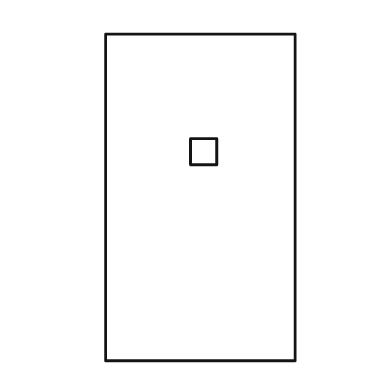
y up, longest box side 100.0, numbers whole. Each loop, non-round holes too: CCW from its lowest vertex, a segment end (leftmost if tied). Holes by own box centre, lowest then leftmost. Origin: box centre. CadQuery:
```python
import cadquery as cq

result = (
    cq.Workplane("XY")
    .moveTo(-29.0, -50.0)
    .lineTo(29.0, -50.0)
    .lineTo(29.0, 50.0)
    .lineTo(-29.0, 50.0)
    .close()
    .moveTo(-3.0, 10.0)
    .lineTo(5.0, 10.0)
    .lineTo(5.0, 18.0)
    .lineTo(-3.0, 18.0)
    .close()
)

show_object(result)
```